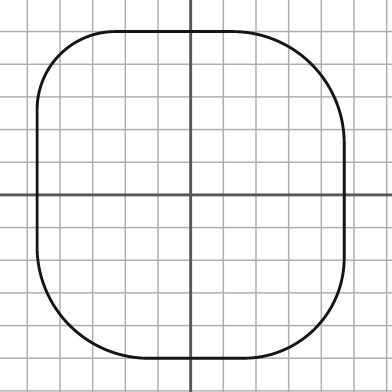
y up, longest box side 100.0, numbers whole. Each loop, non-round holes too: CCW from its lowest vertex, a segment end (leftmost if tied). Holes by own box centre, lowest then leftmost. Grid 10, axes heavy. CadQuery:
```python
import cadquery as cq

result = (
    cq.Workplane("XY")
    .moveTo(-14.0, -50.0)
    .lineTo(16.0, -50.0)
    .threePointArc((38.0, -41.0), (47.0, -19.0))
    .lineTo(47.0, 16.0)
    .threePointArc((37.0, 40.0), (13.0, 50.0))
    .lineTo(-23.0, 50.0)
    .threePointArc((-40.0, 43.0), (-47.0, 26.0))
    .lineTo(-47.0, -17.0)
    .threePointArc((-37.0, -40.0), (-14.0, -50.0))
    .close()
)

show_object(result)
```